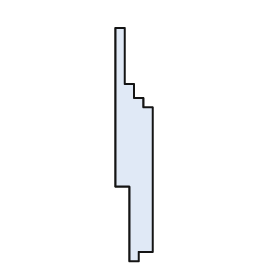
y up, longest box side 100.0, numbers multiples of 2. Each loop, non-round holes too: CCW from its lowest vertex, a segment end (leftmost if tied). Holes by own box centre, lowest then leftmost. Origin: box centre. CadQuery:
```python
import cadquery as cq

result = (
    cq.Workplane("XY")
    .moveTo(-2.0, -50.0)
    .lineTo(2.0, -50.0)
    .lineTo(2.0, -46.0)
    .lineTo(8.0, -46.0)
    .lineTo(8.0, 16.0)
    .lineTo(4.0, 16.0)
    .lineTo(4.0, 20.0)
    .lineTo(0.0, 20.0)
    .lineTo(0.0, 26.0)
    .lineTo(-4.0, 26.0)
    .lineTo(-4.0, 50.0)
    .lineTo(-8.0, 50.0)
    .lineTo(-8.0, -18.0)
    .lineTo(-2.0, -18.0)
    .close()
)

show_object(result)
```